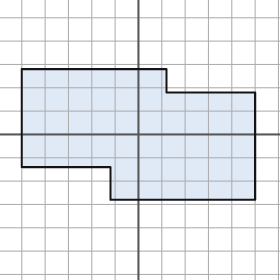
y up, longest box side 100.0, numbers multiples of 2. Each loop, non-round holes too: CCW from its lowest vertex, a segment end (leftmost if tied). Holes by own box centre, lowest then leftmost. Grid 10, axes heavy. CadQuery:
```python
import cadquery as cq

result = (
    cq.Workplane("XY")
    .moveTo(-12.0, -28.0)
    .lineTo(50.0, -28.0)
    .lineTo(50.0, 18.0)
    .lineTo(12.0, 18.0)
    .lineTo(12.0, 28.0)
    .lineTo(-50.0, 28.0)
    .lineTo(-50.0, -14.0)
    .lineTo(-12.0, -14.0)
    .close()
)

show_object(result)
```